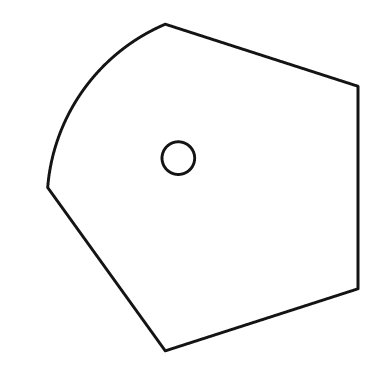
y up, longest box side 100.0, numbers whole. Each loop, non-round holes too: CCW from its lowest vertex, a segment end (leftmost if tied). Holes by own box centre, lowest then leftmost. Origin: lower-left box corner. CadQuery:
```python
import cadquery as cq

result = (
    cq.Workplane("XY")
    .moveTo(36.0, 0.0)
    .lineTo(95.0, 19.0)
    .lineTo(95.0, 81.0)
    .lineTo(36.0, 100.0)
    .threePointArc((11.0, 80.0), (0.0, 50.0))
    .close()
    .moveTo(40.0, 59.0)
    .circle(5.0)
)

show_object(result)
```